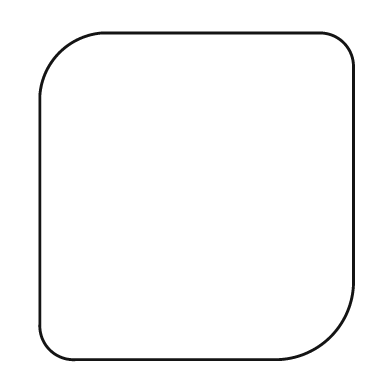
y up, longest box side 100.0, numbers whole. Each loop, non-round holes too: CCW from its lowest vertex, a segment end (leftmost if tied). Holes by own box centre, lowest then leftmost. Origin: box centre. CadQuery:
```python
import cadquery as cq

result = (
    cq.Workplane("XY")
    .moveTo(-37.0, -50.0)
    .lineTo(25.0, -50.0)
    .threePointArc((41.0, -43.0), (48.0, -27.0))
    .lineTo(48.0, 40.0)
    .threePointArc((45.0, 47.0), (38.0, 50.0))
    .lineTo(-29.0, 50.0)
    .threePointArc((-42.0, 44.0), (-48.0, 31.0))
    .lineTo(-48.0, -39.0)
    .threePointArc((-45.0, -47.0), (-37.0, -50.0))
    .close()
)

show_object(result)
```